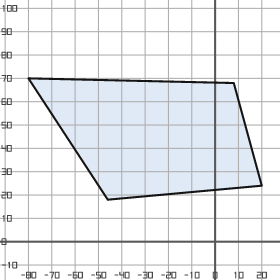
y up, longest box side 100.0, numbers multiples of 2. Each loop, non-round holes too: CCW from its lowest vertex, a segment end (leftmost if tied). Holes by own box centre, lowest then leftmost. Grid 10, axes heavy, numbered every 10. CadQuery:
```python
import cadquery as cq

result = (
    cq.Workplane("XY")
    .moveTo(-46.0, 18.0)
    .lineTo(20.0, 24.0)
    .lineTo(8.0, 68.0)
    .lineTo(-80.0, 70.0)
    .close()
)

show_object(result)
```